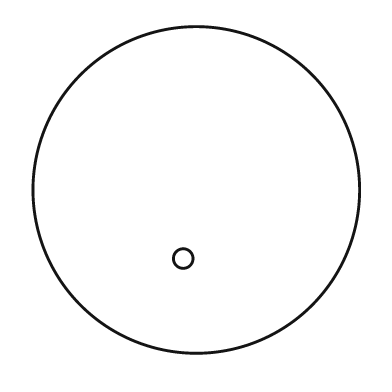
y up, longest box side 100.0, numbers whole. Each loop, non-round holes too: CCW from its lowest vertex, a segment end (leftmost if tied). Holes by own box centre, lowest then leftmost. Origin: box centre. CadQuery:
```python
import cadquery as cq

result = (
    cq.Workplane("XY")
    .moveTo(0.0, 0.0)
    .circle(50.0)
    .moveTo(-4.0, -21.0)
    .circle(3.0)
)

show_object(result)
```